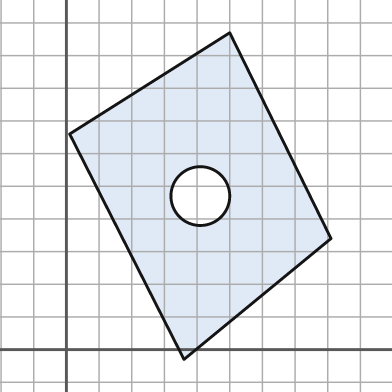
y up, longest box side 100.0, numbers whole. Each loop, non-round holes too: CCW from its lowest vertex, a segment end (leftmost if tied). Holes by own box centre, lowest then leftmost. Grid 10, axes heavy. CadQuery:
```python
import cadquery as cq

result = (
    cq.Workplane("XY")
    .moveTo(36.0, -3.0)
    .lineTo(81.0, 34.0)
    .lineTo(50.0, 97.0)
    .lineTo(1.0, 66.0)
    .close()
    .moveTo(41.0, 47.0)
    .circle(9.0)
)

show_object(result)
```